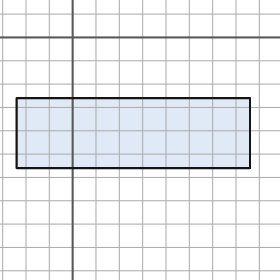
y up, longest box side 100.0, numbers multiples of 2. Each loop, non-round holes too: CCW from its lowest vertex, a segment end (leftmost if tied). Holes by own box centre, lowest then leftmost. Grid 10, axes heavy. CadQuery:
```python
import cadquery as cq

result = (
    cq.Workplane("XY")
    .moveTo(-24.0, -56.0)
    .lineTo(76.0, -56.0)
    .lineTo(76.0, -26.0)
    .lineTo(-24.0, -26.0)
    .close()
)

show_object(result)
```